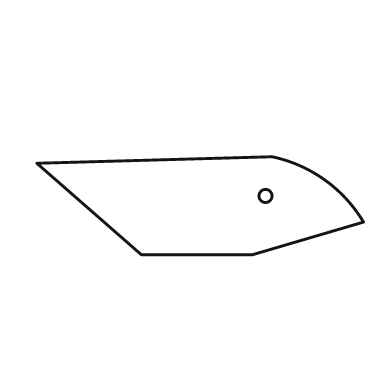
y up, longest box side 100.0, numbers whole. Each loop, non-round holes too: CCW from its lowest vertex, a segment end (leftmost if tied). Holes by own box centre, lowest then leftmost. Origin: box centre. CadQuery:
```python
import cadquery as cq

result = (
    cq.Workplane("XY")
    .moveTo(-18.0, -15.0)
    .lineTo(16.0, -15.0)
    .lineTo(50.0, -5.0)
    .threePointArc((38.0, 8.0), (22.0, 15.0))
    .lineTo(-50.0, 13.0)
    .close()
    .moveTo(20.0, 3.0)
    .circle(2.0)
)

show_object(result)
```